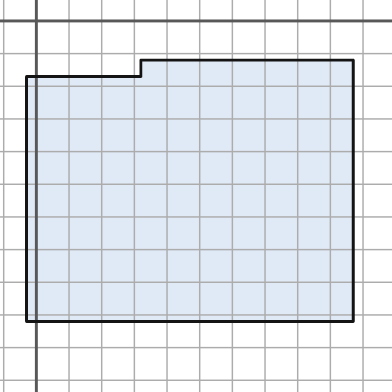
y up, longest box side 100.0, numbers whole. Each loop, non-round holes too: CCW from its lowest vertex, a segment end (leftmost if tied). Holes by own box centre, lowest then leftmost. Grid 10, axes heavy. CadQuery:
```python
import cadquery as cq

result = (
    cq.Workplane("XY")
    .moveTo(-3.0, -92.0)
    .lineTo(97.0, -92.0)
    .lineTo(97.0, -12.0)
    .lineTo(32.0, -12.0)
    .lineTo(32.0, -17.0)
    .lineTo(-3.0, -17.0)
    .close()
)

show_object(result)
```